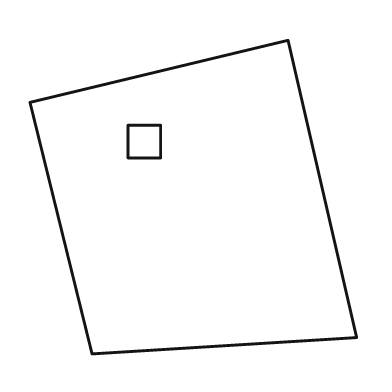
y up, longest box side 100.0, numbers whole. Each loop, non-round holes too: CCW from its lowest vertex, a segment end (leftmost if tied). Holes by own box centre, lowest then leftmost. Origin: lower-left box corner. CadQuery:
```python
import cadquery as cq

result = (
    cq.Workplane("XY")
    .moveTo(19.0, 0.0)
    .lineTo(100.0, 5.0)
    .lineTo(79.0, 96.0)
    .lineTo(0.0, 77.0)
    .close()
    .moveTo(30.0, 60.0)
    .lineTo(40.0, 60.0)
    .lineTo(40.0, 70.0)
    .lineTo(30.0, 70.0)
    .close()
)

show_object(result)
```